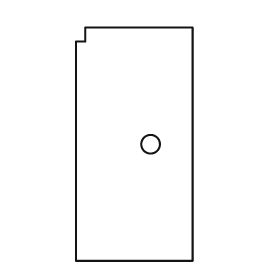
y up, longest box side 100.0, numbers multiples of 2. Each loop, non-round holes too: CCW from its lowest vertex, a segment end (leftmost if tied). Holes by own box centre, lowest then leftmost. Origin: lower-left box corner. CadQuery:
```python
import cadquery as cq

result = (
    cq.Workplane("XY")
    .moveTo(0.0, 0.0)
    .lineTo(50.0, 0.0)
    .lineTo(50.0, 100.0)
    .lineTo(4.0, 100.0)
    .lineTo(4.0, 94.0)
    .lineTo(0.0, 94.0)
    .close()
    .moveTo(32.0, 50.0)
    .circle(4.0)
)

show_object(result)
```